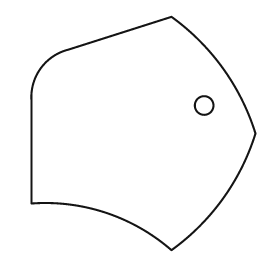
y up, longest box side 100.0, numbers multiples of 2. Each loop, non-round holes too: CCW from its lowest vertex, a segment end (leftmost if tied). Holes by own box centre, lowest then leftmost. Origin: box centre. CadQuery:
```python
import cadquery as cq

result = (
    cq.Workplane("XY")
    .moveTo(12.0, -50.0)
    .threePointArc((34.0, -28.0), (48.0, 0.0))
    .threePointArc((34.0, 28.0), (12.0, 50.0))
    .lineTo(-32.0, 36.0)
    .threePointArc((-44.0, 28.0), (-48.0, 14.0))
    .lineTo(-48.0, -30.0)
    .threePointArc((-16.0, -34.0), (12.0, -50.0))
    .close()
    .moveTo(26.0, 12.0)
    .circle(4.0)
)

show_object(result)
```